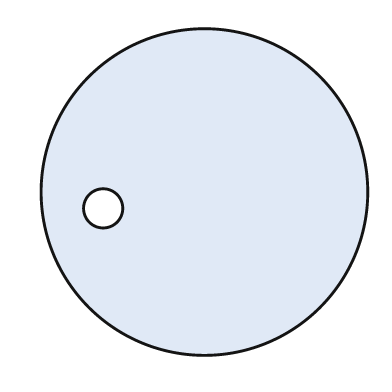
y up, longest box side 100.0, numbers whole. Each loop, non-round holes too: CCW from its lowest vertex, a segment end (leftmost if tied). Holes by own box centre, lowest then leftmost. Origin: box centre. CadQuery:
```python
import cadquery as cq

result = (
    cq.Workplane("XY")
    .moveTo(0.0, 0.0)
    .circle(50.0)
    .moveTo(-31.0, -5.0)
    .circle(6.0)
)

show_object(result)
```